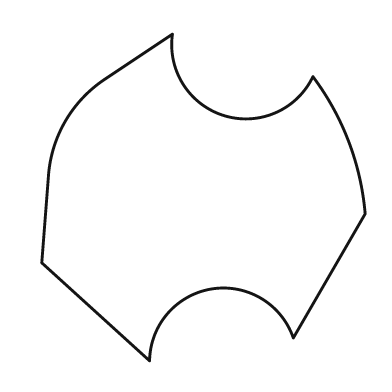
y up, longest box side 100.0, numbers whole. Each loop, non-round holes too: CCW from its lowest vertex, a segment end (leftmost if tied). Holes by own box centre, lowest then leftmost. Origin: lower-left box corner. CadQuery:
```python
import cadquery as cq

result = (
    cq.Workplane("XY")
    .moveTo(33.0, 0.0)
    .threePointArc((52.0, 22.0), (77.0, 7.0))
    .lineTo(99.0, 45.0)
    .threePointArc((94.0, 67.0), (83.0, 87.0))
    .threePointArc((56.0, 75.0), (40.0, 100.0))
    .lineTo(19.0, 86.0)
    .threePointArc((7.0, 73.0), (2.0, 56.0))
    .lineTo(0.0, 30.0)
    .close()
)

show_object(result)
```